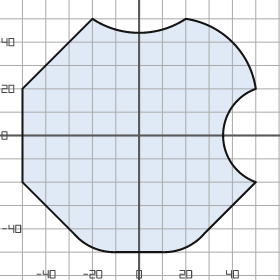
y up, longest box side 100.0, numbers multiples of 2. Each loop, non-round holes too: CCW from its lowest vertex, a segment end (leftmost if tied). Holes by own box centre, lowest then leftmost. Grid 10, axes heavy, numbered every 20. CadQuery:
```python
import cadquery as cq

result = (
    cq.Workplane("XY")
    .moveTo(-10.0, -50.0)
    .lineTo(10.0, -50.0)
    .threePointArc((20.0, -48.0), (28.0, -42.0))
    .lineTo(50.0, -20.0)
    .threePointArc((36.0, 0.0), (50.0, 20.0))
    .threePointArc((40.0, 40.0), (20.0, 50.0))
    .threePointArc((0.0, 44.0), (-20.0, 50.0))
    .lineTo(-50.0, 20.0)
    .lineTo(-50.0, -20.0)
    .lineTo(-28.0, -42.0)
    .threePointArc((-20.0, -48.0), (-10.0, -50.0))
    .close()
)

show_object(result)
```